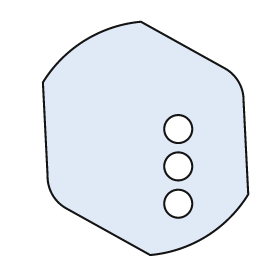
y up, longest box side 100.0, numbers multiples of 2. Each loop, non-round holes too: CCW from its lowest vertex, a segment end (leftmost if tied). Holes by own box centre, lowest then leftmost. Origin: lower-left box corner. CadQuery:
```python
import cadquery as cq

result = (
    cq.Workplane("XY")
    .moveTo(46.0, 0.0)
    .threePointArc((70.0, 8.0), (88.0, 26.0))
    .lineTo(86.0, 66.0)
    .threePointArc((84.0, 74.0), (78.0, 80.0))
    .lineTo(42.0, 100.0)
    .threePointArc((18.0, 92.0), (0.0, 74.0))
    .lineTo(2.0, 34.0)
    .threePointArc((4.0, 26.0), (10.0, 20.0))
    .close()
    .moveTo(58.0, 22.0)
    .circle(6.0)
    .moveTo(58.0, 38.0)
    .circle(6.0)
    .moveTo(58.0, 54.0)
    .circle(6.0)
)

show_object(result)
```